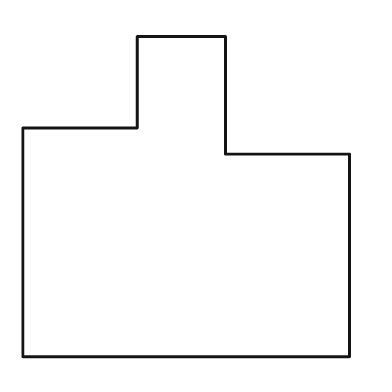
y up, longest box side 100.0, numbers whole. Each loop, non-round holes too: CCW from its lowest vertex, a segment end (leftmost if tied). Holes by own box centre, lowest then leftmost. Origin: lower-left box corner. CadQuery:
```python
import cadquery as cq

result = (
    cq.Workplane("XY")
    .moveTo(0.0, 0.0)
    .lineTo(100.0, 0.0)
    .lineTo(100.0, 62.0)
    .lineTo(62.0, 62.0)
    .lineTo(62.0, 98.0)
    .lineTo(35.0, 98.0)
    .lineTo(35.0, 70.0)
    .lineTo(0.0, 70.0)
    .close()
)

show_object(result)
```